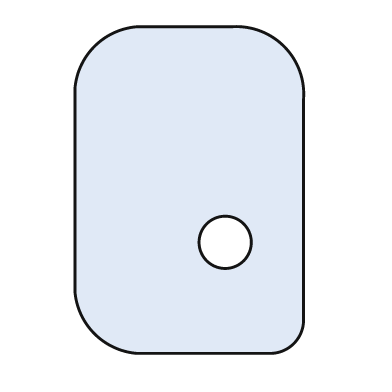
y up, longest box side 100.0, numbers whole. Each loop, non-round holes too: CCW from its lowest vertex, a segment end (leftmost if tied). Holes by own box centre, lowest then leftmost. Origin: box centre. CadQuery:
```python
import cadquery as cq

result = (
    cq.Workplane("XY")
    .moveTo(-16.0, -50.0)
    .lineTo(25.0, -50.0)
    .threePointArc((32.0, -47.0), (35.0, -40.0))
    .lineTo(35.0, 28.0)
    .threePointArc((29.0, 44.0), (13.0, 50.0))
    .lineTo(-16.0, 50.0)
    .threePointArc((-29.0, 44.0), (-35.0, 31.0))
    .lineTo(-35.0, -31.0)
    .threePointArc((-29.0, -44.0), (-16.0, -50.0))
    .close()
    .moveTo(11.0, -16.0)
    .circle(8.0)
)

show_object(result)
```